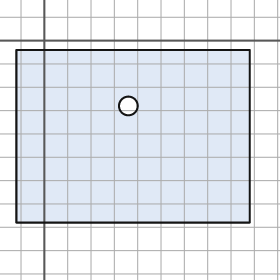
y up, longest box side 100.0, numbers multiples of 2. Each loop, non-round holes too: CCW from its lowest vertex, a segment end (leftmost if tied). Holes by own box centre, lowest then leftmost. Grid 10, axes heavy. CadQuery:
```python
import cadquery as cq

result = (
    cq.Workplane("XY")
    .moveTo(-12.0, -78.0)
    .lineTo(88.0, -78.0)
    .lineTo(88.0, -4.0)
    .lineTo(-12.0, -4.0)
    .close()
    .moveTo(36.0, -28.0)
    .circle(4.0)
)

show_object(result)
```